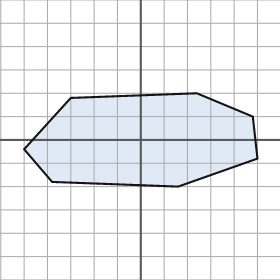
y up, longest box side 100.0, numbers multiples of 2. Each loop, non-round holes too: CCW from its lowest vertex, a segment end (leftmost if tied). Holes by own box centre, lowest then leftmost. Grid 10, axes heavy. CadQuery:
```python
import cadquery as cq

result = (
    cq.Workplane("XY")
    .moveTo(16.0, -20.0)
    .lineTo(50.0, -8.0)
    .lineTo(48.0, 10.0)
    .lineTo(24.0, 20.0)
    .lineTo(-30.0, 18.0)
    .lineTo(-50.0, -4.0)
    .lineTo(-38.0, -18.0)
    .close()
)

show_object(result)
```